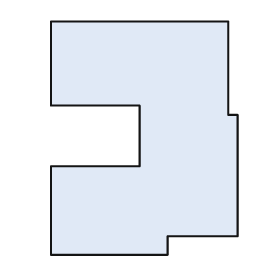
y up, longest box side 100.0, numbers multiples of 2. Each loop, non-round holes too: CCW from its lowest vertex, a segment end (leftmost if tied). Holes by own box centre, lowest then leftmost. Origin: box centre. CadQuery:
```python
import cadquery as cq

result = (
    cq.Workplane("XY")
    .moveTo(-40.0, -50.0)
    .lineTo(10.0, -50.0)
    .lineTo(10.0, -42.0)
    .lineTo(40.0, -42.0)
    .lineTo(40.0, 10.0)
    .lineTo(36.0, 10.0)
    .lineTo(36.0, 50.0)
    .lineTo(-40.0, 50.0)
    .lineTo(-40.0, 14.0)
    .lineTo(-2.0, 14.0)
    .lineTo(-2.0, -12.0)
    .lineTo(-40.0, -12.0)
    .close()
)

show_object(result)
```